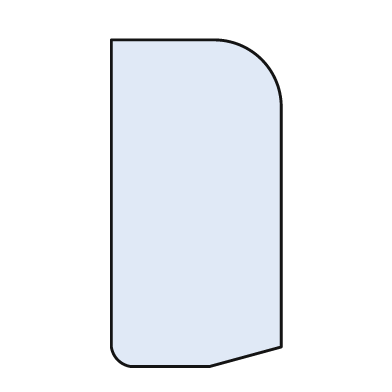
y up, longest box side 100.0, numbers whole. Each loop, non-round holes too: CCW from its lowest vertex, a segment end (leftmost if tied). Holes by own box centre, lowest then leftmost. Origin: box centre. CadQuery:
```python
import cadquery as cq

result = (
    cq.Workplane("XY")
    .moveTo(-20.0, -50.0)
    .lineTo(4.0, -50.0)
    .lineTo(26.0, -44.0)
    .lineTo(26.0, 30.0)
    .threePointArc((20.0, 44.0), (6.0, 50.0))
    .lineTo(-26.0, 50.0)
    .lineTo(-26.0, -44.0)
    .threePointArc((-24.0, -48.0), (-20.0, -50.0))
    .close()
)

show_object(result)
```